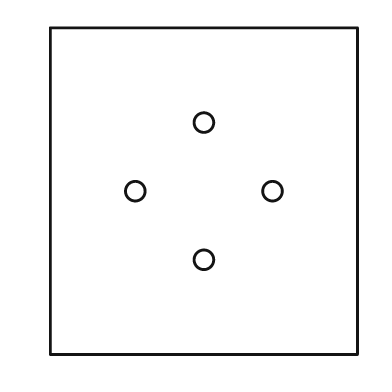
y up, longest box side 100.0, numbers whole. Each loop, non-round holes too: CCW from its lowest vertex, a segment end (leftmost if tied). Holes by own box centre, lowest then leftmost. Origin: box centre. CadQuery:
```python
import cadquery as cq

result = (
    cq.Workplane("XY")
    .moveTo(-47.0, -50.0)
    .lineTo(47.0, -50.0)
    .lineTo(47.0, 50.0)
    .lineTo(-47.0, 50.0)
    .close()
    .moveTo(0.0, -21.0)
    .circle(3.0)
    .moveTo(-21.0, 0.0)
    .circle(3.0)
    .moveTo(21.0, 0.0)
    .circle(3.0)
    .moveTo(0.0, 21.0)
    .circle(3.0)
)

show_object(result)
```